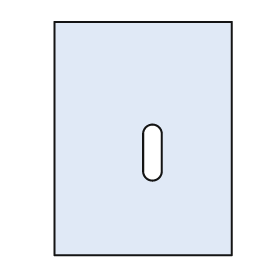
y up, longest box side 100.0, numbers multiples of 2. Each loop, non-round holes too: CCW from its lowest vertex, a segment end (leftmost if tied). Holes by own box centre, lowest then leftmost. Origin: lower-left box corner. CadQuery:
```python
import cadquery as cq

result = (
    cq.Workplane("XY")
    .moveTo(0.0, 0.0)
    .lineTo(76.0, 0.0)
    .lineTo(76.0, 100.0)
    .lineTo(0.0, 100.0)
    .close()
    .moveTo(38.0, 36.0)
    .threePointArc((42.0, 32.0), (46.0, 36.0))
    .lineTo(46.0, 52.0)
    .threePointArc((42.0, 56.0), (38.0, 52.0))
    .close()
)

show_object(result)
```